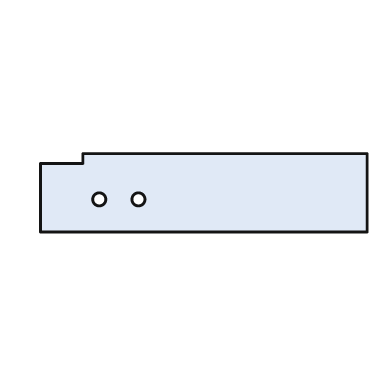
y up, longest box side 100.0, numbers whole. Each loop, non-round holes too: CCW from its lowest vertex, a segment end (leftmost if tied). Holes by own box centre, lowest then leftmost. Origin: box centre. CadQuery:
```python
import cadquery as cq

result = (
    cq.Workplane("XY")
    .moveTo(-50.0, -12.0)
    .lineTo(50.0, -12.0)
    .lineTo(50.0, 12.0)
    .lineTo(-37.0, 12.0)
    .lineTo(-37.0, 9.0)
    .lineTo(-50.0, 9.0)
    .close()
    .moveTo(-32.0, -2.0)
    .circle(2.0)
    .moveTo(-20.0, -2.0)
    .circle(2.0)
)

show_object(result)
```